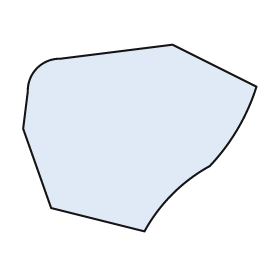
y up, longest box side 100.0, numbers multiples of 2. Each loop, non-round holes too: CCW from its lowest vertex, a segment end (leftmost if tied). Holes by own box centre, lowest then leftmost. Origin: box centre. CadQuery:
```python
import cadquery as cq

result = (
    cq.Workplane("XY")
    .moveTo(2.0, -40.0)
    .threePointArc((14.0, -24.0), (30.0, -12.0))
    .threePointArc((42.0, 4.0), (50.0, 22.0))
    .lineTo(14.0, 40.0)
    .lineTo(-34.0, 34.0)
    .threePointArc((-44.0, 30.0), (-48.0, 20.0))
    .lineTo(-50.0, 4.0)
    .lineTo(-38.0, -30.0)
    .close()
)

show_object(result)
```